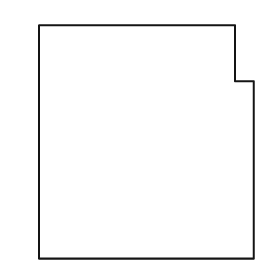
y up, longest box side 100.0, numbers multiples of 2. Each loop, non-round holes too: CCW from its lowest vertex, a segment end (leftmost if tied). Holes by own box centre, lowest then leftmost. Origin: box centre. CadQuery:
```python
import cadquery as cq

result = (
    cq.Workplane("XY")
    .moveTo(-46.0, -50.0)
    .lineTo(46.0, -50.0)
    .lineTo(46.0, 26.0)
    .lineTo(38.0, 26.0)
    .lineTo(38.0, 50.0)
    .lineTo(-46.0, 50.0)
    .close()
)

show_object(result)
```